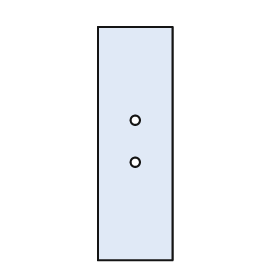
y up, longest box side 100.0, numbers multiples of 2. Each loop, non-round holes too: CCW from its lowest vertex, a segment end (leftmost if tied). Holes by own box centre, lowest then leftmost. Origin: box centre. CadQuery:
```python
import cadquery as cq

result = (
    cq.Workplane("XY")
    .moveTo(-16.0, -50.0)
    .lineTo(16.0, -50.0)
    .lineTo(16.0, 50.0)
    .lineTo(-16.0, 50.0)
    .close()
    .moveTo(0.0, -8.0)
    .circle(2.0)
    .moveTo(0.0, 10.0)
    .circle(2.0)
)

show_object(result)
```